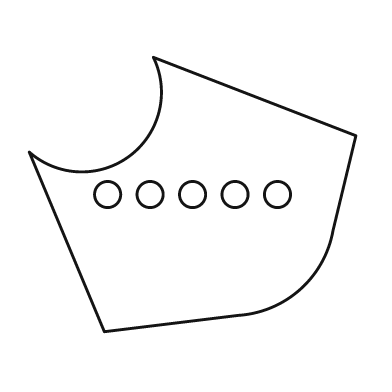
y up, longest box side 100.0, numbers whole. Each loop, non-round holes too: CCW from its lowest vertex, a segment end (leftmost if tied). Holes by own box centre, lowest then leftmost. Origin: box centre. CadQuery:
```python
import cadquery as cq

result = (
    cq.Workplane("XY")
    .moveTo(-27.0, -42.0)
    .lineTo(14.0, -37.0)
    .threePointArc((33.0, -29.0), (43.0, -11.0))
    .lineTo(50.0, 18.0)
    .lineTo(-12.0, 42.0)
    .threePointArc((-19.0, 12.0), (-50.0, 13.0))
    .close()
    .moveTo(-26.0, 0.0)
    .circle(4.0)
    .moveTo(-13.0, 0.0)
    .circle(4.0)
    .moveTo(0.0, 0.0)
    .circle(4.0)
    .moveTo(13.0, 0.0)
    .circle(4.0)
    .moveTo(26.0, 0.0)
    .circle(4.0)
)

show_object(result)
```